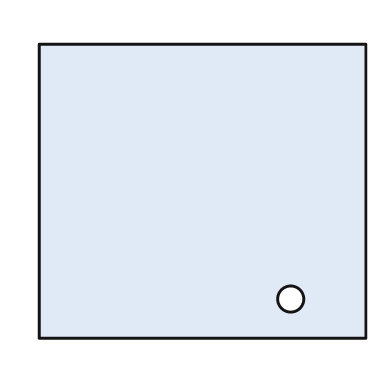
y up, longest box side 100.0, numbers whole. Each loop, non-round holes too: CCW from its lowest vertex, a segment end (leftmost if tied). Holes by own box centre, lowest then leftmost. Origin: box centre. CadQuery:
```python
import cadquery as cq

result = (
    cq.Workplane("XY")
    .moveTo(-50.0, -45.0)
    .lineTo(50.0, -45.0)
    .lineTo(50.0, 45.0)
    .lineTo(-50.0, 45.0)
    .close()
    .moveTo(27.0, -33.0)
    .circle(4.0)
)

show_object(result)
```